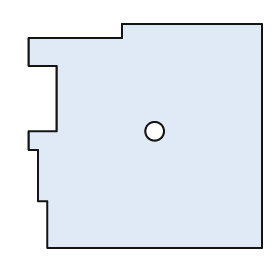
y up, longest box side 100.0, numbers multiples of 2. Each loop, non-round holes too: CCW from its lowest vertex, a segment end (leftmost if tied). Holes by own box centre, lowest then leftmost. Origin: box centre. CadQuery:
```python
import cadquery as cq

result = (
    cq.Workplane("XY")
    .moveTo(-42.0, -48.0)
    .lineTo(50.0, -48.0)
    .lineTo(50.0, 48.0)
    .lineTo(-10.0, 48.0)
    .lineTo(-10.0, 42.0)
    .lineTo(-50.0, 42.0)
    .lineTo(-50.0, 30.0)
    .lineTo(-38.0, 30.0)
    .lineTo(-38.0, 2.0)
    .lineTo(-50.0, 2.0)
    .lineTo(-50.0, -6.0)
    .lineTo(-46.0, -6.0)
    .lineTo(-46.0, -28.0)
    .lineTo(-42.0, -28.0)
    .close()
    .moveTo(4.0, 2.0)
    .circle(4.0)
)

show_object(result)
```